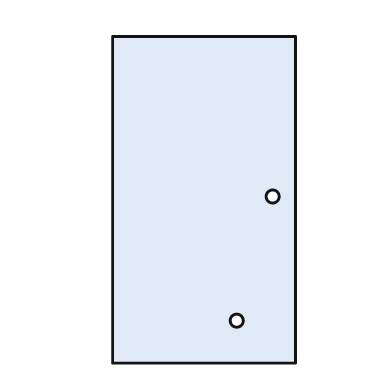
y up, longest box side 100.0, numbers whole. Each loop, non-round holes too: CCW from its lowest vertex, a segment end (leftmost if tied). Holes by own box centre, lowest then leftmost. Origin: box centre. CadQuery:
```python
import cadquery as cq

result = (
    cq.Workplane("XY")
    .moveTo(-28.0, -50.0)
    .lineTo(28.0, -50.0)
    .lineTo(28.0, 50.0)
    .lineTo(-28.0, 50.0)
    .close()
    .moveTo(10.0, -37.0)
    .circle(2.0)
    .moveTo(21.0, 1.0)
    .circle(2.0)
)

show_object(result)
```